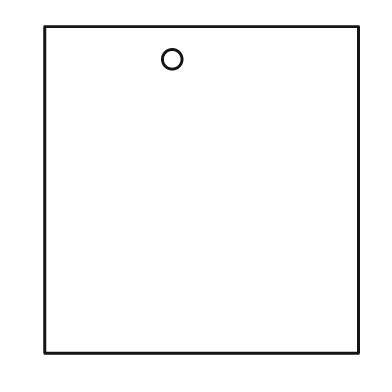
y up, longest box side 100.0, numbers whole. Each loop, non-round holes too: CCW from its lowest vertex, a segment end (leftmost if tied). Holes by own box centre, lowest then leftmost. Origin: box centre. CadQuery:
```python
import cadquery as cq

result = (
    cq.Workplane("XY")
    .moveTo(-48.0, -50.0)
    .lineTo(48.0, -50.0)
    .lineTo(48.0, 50.0)
    .lineTo(-48.0, 50.0)
    .close()
    .moveTo(-9.0, 40.0)
    .circle(3.0)
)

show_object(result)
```